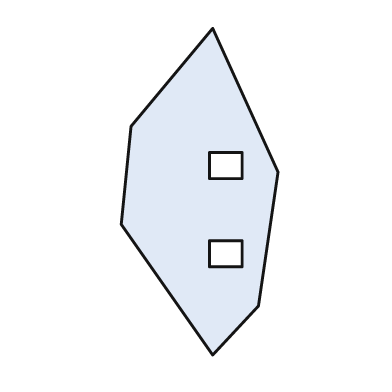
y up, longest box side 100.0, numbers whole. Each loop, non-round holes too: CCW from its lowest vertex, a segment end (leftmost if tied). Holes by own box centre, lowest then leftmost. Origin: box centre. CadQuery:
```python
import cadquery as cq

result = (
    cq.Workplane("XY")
    .moveTo(4.0, -50.0)
    .lineTo(18.0, -35.0)
    .lineTo(24.0, 6.0)
    .lineTo(4.0, 50.0)
    .lineTo(-21.0, 20.0)
    .lineTo(-24.0, -10.0)
    .close()
    .moveTo(3.0, -23.0)
    .lineTo(13.0, -23.0)
    .lineTo(13.0, -15.0)
    .lineTo(3.0, -15.0)
    .close()
    .moveTo(3.0, 4.0)
    .lineTo(13.0, 4.0)
    .lineTo(13.0, 12.0)
    .lineTo(3.0, 12.0)
    .close()
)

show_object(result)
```